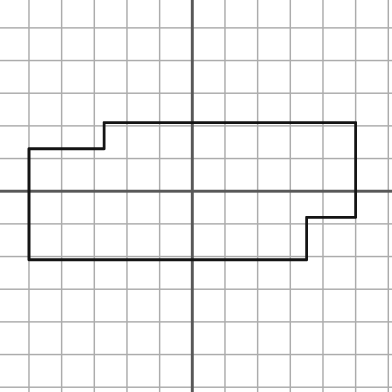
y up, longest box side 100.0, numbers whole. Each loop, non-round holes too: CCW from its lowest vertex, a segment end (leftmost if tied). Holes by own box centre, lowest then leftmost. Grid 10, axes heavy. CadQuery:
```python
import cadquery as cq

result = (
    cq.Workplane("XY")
    .moveTo(-50.0, -21.0)
    .lineTo(35.0, -21.0)
    .lineTo(35.0, -8.0)
    .lineTo(50.0, -8.0)
    .lineTo(50.0, 21.0)
    .lineTo(-27.0, 21.0)
    .lineTo(-27.0, 13.0)
    .lineTo(-50.0, 13.0)
    .close()
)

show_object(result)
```